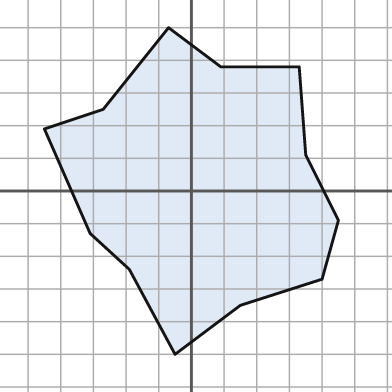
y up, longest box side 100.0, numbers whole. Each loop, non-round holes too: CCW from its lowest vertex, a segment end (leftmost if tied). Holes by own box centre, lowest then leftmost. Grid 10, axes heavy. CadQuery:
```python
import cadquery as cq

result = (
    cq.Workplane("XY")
    .moveTo(-5.0, -50.0)
    .lineTo(15.0, -35.0)
    .lineTo(40.0, -27.0)
    .lineTo(45.0, -9.0)
    .lineTo(35.0, 11.0)
    .lineTo(33.0, 38.0)
    .lineTo(9.0, 38.0)
    .lineTo(-7.0, 50.0)
    .lineTo(-27.0, 25.0)
    .lineTo(-45.0, 19.0)
    .lineTo(-31.0, -13.0)
    .lineTo(-19.0, -24.0)
    .close()
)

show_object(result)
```